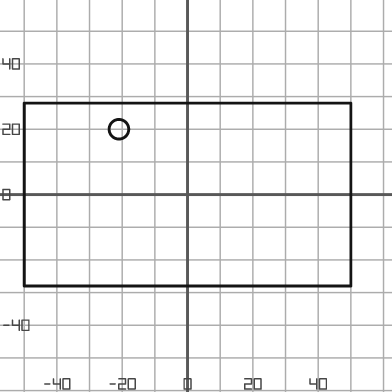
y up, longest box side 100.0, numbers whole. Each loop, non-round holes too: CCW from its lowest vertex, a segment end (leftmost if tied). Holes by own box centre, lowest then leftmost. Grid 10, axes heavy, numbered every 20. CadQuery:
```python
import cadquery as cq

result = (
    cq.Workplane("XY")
    .moveTo(-50.0, -28.0)
    .lineTo(50.0, -28.0)
    .lineTo(50.0, 28.0)
    .lineTo(-50.0, 28.0)
    .close()
    .moveTo(-21.0, 20.0)
    .circle(3.0)
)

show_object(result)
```